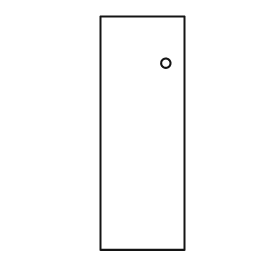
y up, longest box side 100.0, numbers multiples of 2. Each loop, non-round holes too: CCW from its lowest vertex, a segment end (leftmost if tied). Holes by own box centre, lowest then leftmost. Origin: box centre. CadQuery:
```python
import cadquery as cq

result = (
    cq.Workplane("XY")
    .moveTo(-18.0, -50.0)
    .lineTo(18.0, -50.0)
    .lineTo(18.0, 50.0)
    .lineTo(-18.0, 50.0)
    .close()
    .moveTo(10.0, 30.0)
    .circle(2.0)
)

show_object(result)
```